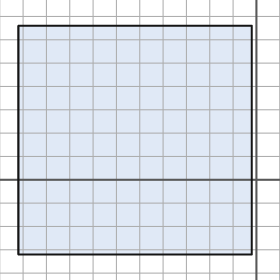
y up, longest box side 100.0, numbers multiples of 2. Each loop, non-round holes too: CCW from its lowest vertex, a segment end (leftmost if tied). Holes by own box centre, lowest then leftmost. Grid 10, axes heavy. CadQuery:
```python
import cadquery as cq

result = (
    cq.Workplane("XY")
    .moveTo(-102.0, -32.0)
    .lineTo(-2.0, -32.0)
    .lineTo(-2.0, 66.0)
    .lineTo(-102.0, 66.0)
    .close()
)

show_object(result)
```